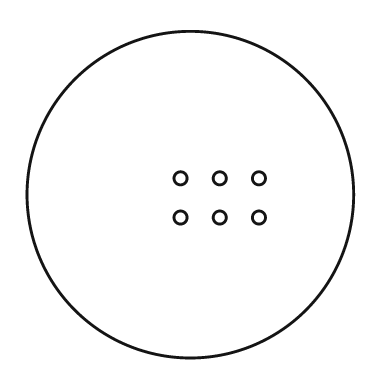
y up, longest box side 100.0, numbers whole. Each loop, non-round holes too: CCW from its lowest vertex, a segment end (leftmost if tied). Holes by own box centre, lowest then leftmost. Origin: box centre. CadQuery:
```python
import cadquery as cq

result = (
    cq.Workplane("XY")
    .moveTo(0.0, 0.0)
    .circle(50.0)
    .moveTo(-3.0, -7.0)
    .circle(2.0)
    .moveTo(9.0, -7.0)
    .circle(2.0)
    .moveTo(21.0, -7.0)
    .circle(2.0)
    .moveTo(-3.0, 5.0)
    .circle(2.0)
    .moveTo(9.0, 5.0)
    .circle(2.0)
    .moveTo(21.0, 5.0)
    .circle(2.0)
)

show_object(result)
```